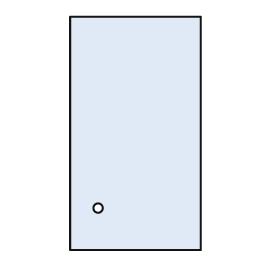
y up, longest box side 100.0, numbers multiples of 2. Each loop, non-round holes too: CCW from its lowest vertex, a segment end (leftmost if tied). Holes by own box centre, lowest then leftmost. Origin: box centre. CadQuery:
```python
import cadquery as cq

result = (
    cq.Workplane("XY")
    .moveTo(-28.0, -50.0)
    .lineTo(28.0, -50.0)
    .lineTo(28.0, 50.0)
    .lineTo(-28.0, 50.0)
    .close()
    .moveTo(-16.0, -32.0)
    .circle(2.0)
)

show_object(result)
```